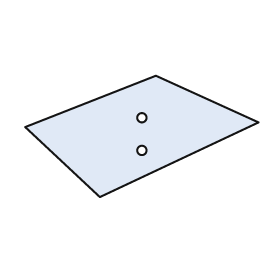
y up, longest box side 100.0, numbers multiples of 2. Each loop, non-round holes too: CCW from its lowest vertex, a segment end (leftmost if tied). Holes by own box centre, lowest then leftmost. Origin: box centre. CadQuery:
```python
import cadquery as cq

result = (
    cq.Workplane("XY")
    .moveTo(-18.0, -26.0)
    .lineTo(50.0, 6.0)
    .lineTo(6.0, 26.0)
    .lineTo(-50.0, 4.0)
    .close()
    .moveTo(0.0, -6.0)
    .circle(2.0)
    .moveTo(0.0, 8.0)
    .circle(2.0)
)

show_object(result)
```